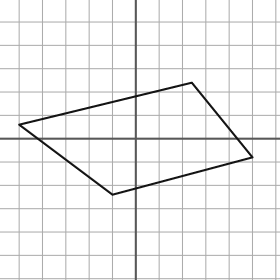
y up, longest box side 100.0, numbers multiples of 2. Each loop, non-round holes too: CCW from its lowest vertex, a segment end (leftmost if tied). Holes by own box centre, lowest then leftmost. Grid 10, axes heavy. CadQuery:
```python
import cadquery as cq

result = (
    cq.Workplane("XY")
    .moveTo(-10.0, -24.0)
    .lineTo(50.0, -8.0)
    .lineTo(24.0, 24.0)
    .lineTo(-50.0, 6.0)
    .close()
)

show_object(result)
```